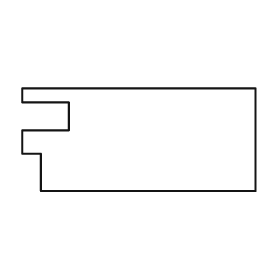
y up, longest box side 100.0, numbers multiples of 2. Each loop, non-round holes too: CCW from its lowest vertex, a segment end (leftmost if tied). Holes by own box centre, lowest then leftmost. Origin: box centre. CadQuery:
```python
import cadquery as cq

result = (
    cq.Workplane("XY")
    .moveTo(-42.0, -22.0)
    .lineTo(50.0, -22.0)
    .lineTo(50.0, 22.0)
    .lineTo(-50.0, 22.0)
    .lineTo(-50.0, 16.0)
    .lineTo(-30.0, 16.0)
    .lineTo(-30.0, 4.0)
    .lineTo(-50.0, 4.0)
    .lineTo(-50.0, -6.0)
    .lineTo(-42.0, -6.0)
    .close()
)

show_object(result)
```